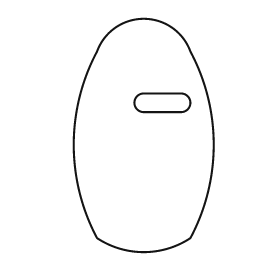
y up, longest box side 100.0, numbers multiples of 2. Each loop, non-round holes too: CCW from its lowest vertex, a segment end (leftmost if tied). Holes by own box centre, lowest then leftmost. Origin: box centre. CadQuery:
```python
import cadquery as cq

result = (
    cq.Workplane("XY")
    .moveTo(-20.0, -44.0)
    .threePointArc((0.0, -50.0), (20.0, -44.0))
    .threePointArc((30.0, -4.0), (20.0, 36.0))
    .threePointArc((0.0, 50.0), (-20.0, 36.0))
    .threePointArc((-30.0, -4.0), (-20.0, -44.0))
    .close()
    .moveTo(0.0, 10.0)
    .lineTo(16.0, 10.0)
    .threePointArc((20.0, 14.0), (16.0, 18.0))
    .lineTo(0.0, 18.0)
    .threePointArc((-4.0, 14.0), (0.0, 10.0))
    .close()
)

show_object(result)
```